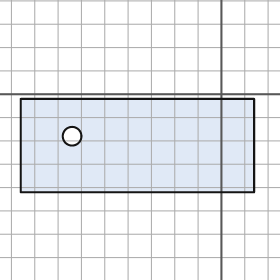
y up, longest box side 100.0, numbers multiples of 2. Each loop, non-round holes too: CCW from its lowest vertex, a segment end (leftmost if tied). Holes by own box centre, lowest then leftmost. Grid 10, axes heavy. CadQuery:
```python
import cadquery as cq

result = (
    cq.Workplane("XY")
    .moveTo(-86.0, -42.0)
    .lineTo(14.0, -42.0)
    .lineTo(14.0, -2.0)
    .lineTo(-86.0, -2.0)
    .close()
    .moveTo(-64.0, -18.0)
    .circle(4.0)
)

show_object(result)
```